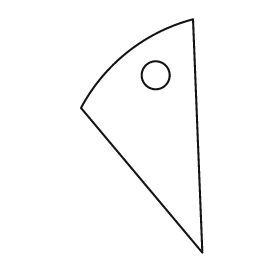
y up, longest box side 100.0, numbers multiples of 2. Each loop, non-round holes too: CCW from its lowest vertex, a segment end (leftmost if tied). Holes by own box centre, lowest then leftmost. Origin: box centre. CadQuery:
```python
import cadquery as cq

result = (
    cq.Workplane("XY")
    .moveTo(26.0, -50.0)
    .lineTo(22.0, 50.0)
    .threePointArc((-6.0, 36.0), (-26.0, 12.0))
    .close()
    .moveTo(6.0, 26.0)
    .circle(6.0)
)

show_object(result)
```